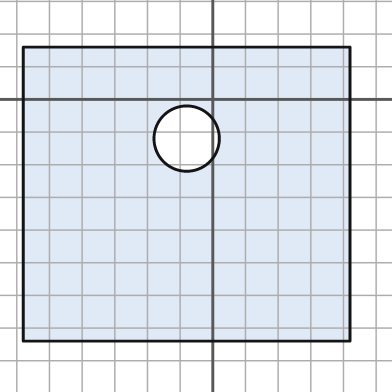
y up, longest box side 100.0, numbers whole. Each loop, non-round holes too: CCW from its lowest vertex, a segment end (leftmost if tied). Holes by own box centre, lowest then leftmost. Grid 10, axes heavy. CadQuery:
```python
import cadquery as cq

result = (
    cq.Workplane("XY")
    .moveTo(-58.0, -74.0)
    .lineTo(42.0, -74.0)
    .lineTo(42.0, 16.0)
    .lineTo(-58.0, 16.0)
    .close()
    .moveTo(-8.0, -12.0)
    .circle(10.0)
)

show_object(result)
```